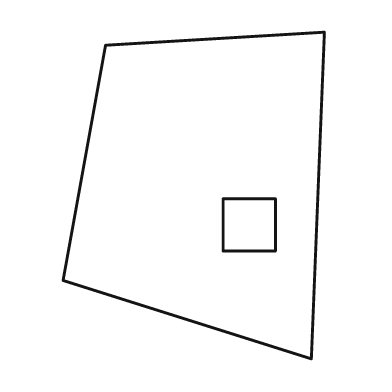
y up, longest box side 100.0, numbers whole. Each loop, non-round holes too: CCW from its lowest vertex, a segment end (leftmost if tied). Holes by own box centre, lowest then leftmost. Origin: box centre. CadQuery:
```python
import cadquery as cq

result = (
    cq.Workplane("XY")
    .moveTo(36.0, -50.0)
    .lineTo(40.0, 50.0)
    .lineTo(-27.0, 46.0)
    .lineTo(-40.0, -26.0)
    .close()
    .moveTo(9.0, -17.0)
    .lineTo(25.0, -17.0)
    .lineTo(25.0, -1.0)
    .lineTo(9.0, -1.0)
    .close()
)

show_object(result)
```